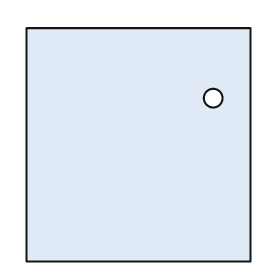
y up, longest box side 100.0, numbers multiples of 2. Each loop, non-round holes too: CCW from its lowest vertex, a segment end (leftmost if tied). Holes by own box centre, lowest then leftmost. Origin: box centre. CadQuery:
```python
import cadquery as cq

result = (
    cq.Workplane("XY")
    .moveTo(-48.0, -50.0)
    .lineTo(48.0, -50.0)
    .lineTo(48.0, 50.0)
    .lineTo(-48.0, 50.0)
    .close()
    .moveTo(32.0, 20.0)
    .circle(4.0)
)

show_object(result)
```